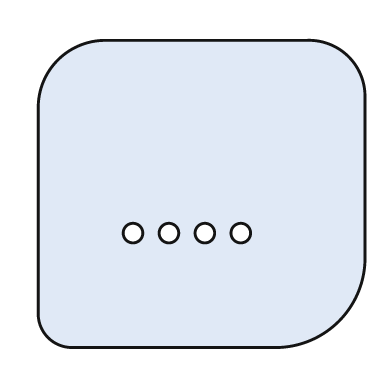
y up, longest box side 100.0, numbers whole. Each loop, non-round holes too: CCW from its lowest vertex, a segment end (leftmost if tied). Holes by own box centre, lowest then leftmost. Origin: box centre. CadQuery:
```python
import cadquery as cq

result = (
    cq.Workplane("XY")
    .moveTo(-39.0, -47.0)
    .lineTo(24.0, -47.0)
    .threePointArc((42.0, -39.0), (50.0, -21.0))
    .lineTo(50.0, 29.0)
    .threePointArc((45.0, 42.0), (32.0, 47.0))
    .lineTo(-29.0, 47.0)
    .threePointArc((-44.0, 41.0), (-50.0, 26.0))
    .lineTo(-50.0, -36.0)
    .threePointArc((-47.0, -44.0), (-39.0, -47.0))
    .close()
    .moveTo(-21.0, -12.0)
    .circle(3.0)
    .moveTo(-10.0, -12.0)
    .circle(3.0)
    .moveTo(1.0, -12.0)
    .circle(3.0)
    .moveTo(12.0, -12.0)
    .circle(3.0)
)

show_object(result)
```